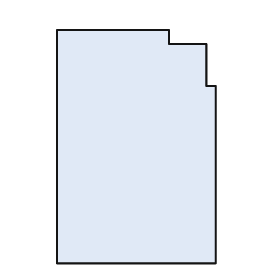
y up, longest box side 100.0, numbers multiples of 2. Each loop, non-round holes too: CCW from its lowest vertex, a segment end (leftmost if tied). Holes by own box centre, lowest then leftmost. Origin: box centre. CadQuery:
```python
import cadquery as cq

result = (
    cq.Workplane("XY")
    .moveTo(-34.0, -50.0)
    .lineTo(34.0, -50.0)
    .lineTo(34.0, 26.0)
    .lineTo(30.0, 26.0)
    .lineTo(30.0, 44.0)
    .lineTo(14.0, 44.0)
    .lineTo(14.0, 50.0)
    .lineTo(-34.0, 50.0)
    .close()
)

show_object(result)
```